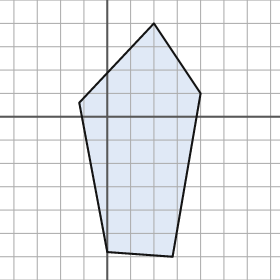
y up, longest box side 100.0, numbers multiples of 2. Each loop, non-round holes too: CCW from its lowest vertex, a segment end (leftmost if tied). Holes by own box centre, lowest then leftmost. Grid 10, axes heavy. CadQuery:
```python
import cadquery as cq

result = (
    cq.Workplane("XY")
    .moveTo(28.0, -60.0)
    .lineTo(40.0, 10.0)
    .lineTo(20.0, 40.0)
    .lineTo(-12.0, 6.0)
    .lineTo(0.0, -58.0)
    .close()
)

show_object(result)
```